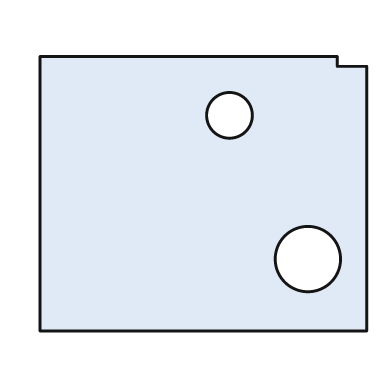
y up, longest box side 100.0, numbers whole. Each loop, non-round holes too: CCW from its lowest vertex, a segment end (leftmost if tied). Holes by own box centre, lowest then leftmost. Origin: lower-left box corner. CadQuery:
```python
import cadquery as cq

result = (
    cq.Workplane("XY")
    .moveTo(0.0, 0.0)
    .lineTo(100.0, 0.0)
    .lineTo(100.0, 81.0)
    .lineTo(91.0, 81.0)
    .lineTo(91.0, 84.0)
    .lineTo(0.0, 84.0)
    .close()
    .moveTo(82.0, 22.0)
    .circle(10.0)
    .moveTo(58.0, 66.0)
    .circle(7.0)
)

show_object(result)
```